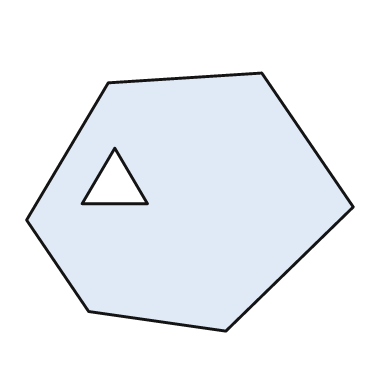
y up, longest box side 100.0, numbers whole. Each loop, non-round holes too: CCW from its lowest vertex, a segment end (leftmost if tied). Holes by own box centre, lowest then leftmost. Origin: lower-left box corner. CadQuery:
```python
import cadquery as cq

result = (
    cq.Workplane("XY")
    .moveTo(61.0, 0.0)
    .lineTo(100.0, 38.0)
    .lineTo(72.0, 79.0)
    .lineTo(25.0, 76.0)
    .lineTo(0.0, 34.0)
    .lineTo(19.0, 6.0)
    .close()
    .moveTo(17.0, 39.0)
    .lineTo(37.0, 39.0)
    .lineTo(27.0, 56.0)
    .close()
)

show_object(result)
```